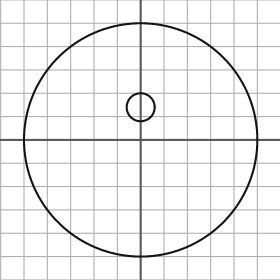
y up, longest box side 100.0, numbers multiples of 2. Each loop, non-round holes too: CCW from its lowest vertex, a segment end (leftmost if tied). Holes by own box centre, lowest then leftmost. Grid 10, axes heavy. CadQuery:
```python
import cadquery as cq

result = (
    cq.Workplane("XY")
    .moveTo(0.0, 0.0)
    .circle(50.0)
    .moveTo(0.0, 14.0)
    .circle(6.0)
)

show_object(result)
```